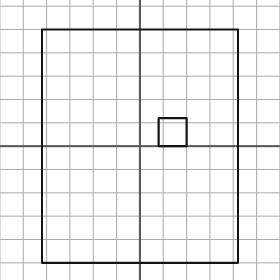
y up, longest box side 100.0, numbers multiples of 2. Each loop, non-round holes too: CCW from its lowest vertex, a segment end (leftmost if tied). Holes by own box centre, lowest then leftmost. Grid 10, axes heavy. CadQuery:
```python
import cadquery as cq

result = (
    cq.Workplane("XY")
    .moveTo(-42.0, -50.0)
    .lineTo(42.0, -50.0)
    .lineTo(42.0, 50.0)
    .lineTo(-42.0, 50.0)
    .close()
    .moveTo(8.0, 0.0)
    .lineTo(20.0, 0.0)
    .lineTo(20.0, 12.0)
    .lineTo(8.0, 12.0)
    .close()
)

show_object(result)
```